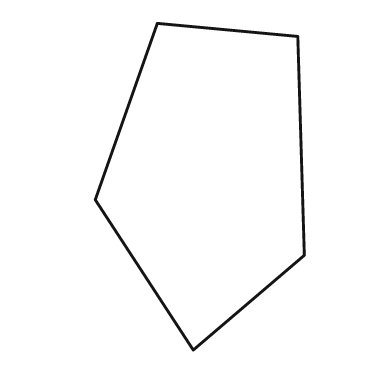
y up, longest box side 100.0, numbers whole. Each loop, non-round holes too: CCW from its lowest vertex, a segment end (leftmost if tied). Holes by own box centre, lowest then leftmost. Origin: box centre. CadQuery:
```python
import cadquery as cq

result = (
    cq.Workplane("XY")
    .moveTo(-2.0, -50.0)
    .lineTo(32.0, -21.0)
    .lineTo(30.0, 46.0)
    .lineTo(-13.0, 50.0)
    .lineTo(-32.0, -4.0)
    .close()
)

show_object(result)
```